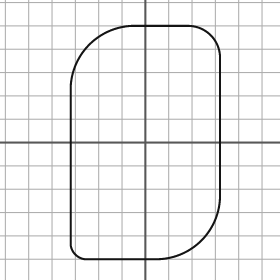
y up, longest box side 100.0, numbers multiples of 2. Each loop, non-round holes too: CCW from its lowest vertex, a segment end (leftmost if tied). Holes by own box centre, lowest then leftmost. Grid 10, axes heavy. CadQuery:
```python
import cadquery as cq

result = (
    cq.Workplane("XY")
    .moveTo(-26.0, -50.0)
    .lineTo(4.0, -50.0)
    .threePointArc((24.0, -42.0), (32.0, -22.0))
    .lineTo(32.0, 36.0)
    .threePointArc((28.0, 46.0), (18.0, 50.0))
    .lineTo(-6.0, 50.0)
    .threePointArc((-24.0, 42.0), (-32.0, 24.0))
    .lineTo(-32.0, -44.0)
    .threePointArc((-30.0, -48.0), (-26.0, -50.0))
    .close()
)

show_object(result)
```